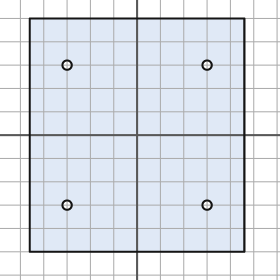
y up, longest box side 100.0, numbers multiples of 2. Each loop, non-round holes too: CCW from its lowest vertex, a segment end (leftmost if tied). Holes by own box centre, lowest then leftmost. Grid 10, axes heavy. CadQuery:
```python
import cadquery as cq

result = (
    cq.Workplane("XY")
    .moveTo(-46.0, -50.0)
    .lineTo(46.0, -50.0)
    .lineTo(46.0, 50.0)
    .lineTo(-46.0, 50.0)
    .close()
    .moveTo(-30.0, -30.0)
    .circle(2.0)
    .moveTo(30.0, -30.0)
    .circle(2.0)
    .moveTo(-30.0, 30.0)
    .circle(2.0)
    .moveTo(30.0, 30.0)
    .circle(2.0)
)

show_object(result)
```